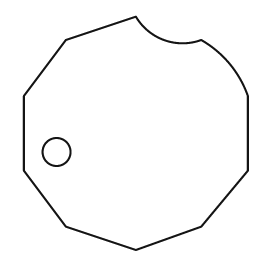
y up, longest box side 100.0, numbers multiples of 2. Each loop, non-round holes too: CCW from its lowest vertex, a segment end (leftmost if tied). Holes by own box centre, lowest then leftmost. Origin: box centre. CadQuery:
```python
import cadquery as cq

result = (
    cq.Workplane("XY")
    .moveTo(0.0, -50.0)
    .lineTo(28.0, -40.0)
    .lineTo(48.0, -16.0)
    .lineTo(48.0, 16.0)
    .threePointArc((40.0, 30.0), (28.0, 40.0))
    .threePointArc((12.0, 40.0), (0.0, 50.0))
    .lineTo(-30.0, 40.0)
    .lineTo(-48.0, 16.0)
    .lineTo(-48.0, -16.0)
    .lineTo(-30.0, -40.0)
    .close()
    .moveTo(-34.0, -8.0)
    .circle(6.0)
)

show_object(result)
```